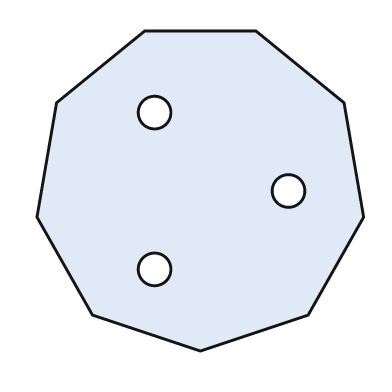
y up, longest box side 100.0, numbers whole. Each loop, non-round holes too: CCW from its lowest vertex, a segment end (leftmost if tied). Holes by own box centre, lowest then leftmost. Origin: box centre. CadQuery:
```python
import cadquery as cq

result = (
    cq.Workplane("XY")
    .moveTo(0.0, -49.0)
    .lineTo(33.0, -38.0)
    .lineTo(50.0, -8.0)
    .lineTo(44.0, 27.0)
    .lineTo(17.0, 49.0)
    .lineTo(-17.0, 49.0)
    .lineTo(-44.0, 27.0)
    .lineTo(-50.0, -8.0)
    .lineTo(-33.0, -38.0)
    .close()
    .moveTo(-14.0, -24.0)
    .circle(5.0)
    .moveTo(27.0, 0.0)
    .circle(5.0)
    .moveTo(-14.0, 24.0)
    .circle(5.0)
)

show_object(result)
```